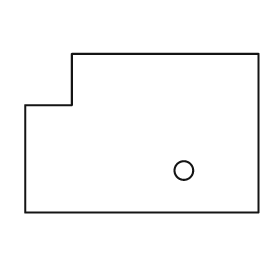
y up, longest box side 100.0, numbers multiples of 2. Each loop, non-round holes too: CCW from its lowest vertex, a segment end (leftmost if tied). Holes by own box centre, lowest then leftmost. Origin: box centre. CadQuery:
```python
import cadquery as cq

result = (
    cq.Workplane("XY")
    .moveTo(-50.0, -34.0)
    .lineTo(50.0, -34.0)
    .lineTo(50.0, 34.0)
    .lineTo(-30.0, 34.0)
    .lineTo(-30.0, 12.0)
    .lineTo(-50.0, 12.0)
    .close()
    .moveTo(18.0, -16.0)
    .circle(4.0)
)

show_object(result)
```